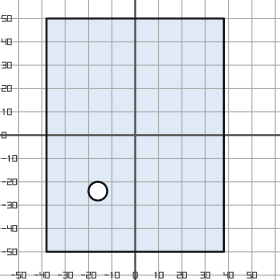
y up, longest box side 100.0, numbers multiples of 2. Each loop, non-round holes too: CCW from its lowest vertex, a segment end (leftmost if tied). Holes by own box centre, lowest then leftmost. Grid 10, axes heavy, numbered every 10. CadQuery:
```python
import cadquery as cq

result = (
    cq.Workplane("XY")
    .moveTo(-38.0, -50.0)
    .lineTo(38.0, -50.0)
    .lineTo(38.0, 50.0)
    .lineTo(-38.0, 50.0)
    .close()
    .moveTo(-16.0, -24.0)
    .circle(4.0)
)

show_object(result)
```